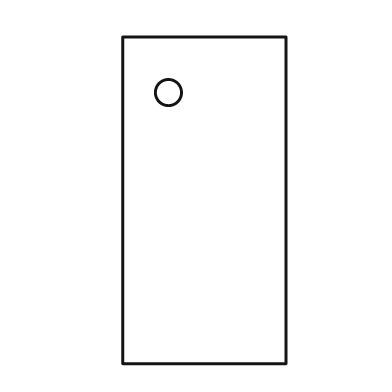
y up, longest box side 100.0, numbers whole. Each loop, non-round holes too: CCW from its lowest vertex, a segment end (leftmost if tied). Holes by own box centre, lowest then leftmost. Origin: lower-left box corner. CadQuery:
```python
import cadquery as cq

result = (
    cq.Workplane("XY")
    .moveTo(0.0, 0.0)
    .lineTo(50.0, 0.0)
    .lineTo(50.0, 100.0)
    .lineTo(0.0, 100.0)
    .close()
    .moveTo(14.0, 83.0)
    .circle(4.0)
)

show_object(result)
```